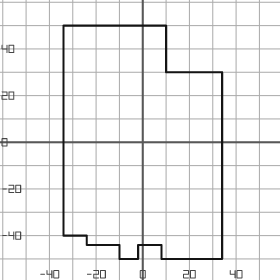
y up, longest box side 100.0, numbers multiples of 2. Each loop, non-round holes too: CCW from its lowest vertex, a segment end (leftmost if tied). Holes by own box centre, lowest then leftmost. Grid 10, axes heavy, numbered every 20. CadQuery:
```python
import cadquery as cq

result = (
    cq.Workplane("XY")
    .moveTo(-10.0, -50.0)
    .lineTo(-2.0, -50.0)
    .lineTo(-2.0, -44.0)
    .lineTo(8.0, -44.0)
    .lineTo(8.0, -50.0)
    .lineTo(34.0, -50.0)
    .lineTo(34.0, 30.0)
    .lineTo(10.0, 30.0)
    .lineTo(10.0, 50.0)
    .lineTo(-34.0, 50.0)
    .lineTo(-34.0, -40.0)
    .lineTo(-24.0, -40.0)
    .lineTo(-24.0, -44.0)
    .lineTo(-10.0, -44.0)
    .close()
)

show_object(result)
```